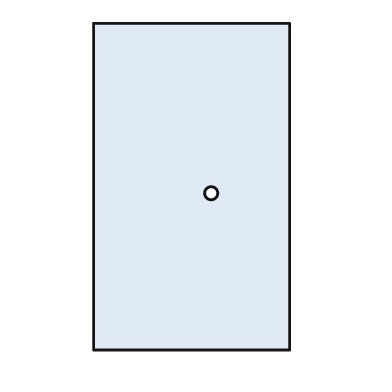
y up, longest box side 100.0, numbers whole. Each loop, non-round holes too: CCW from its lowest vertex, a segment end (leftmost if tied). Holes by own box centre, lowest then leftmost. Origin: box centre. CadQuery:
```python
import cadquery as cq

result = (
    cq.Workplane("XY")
    .moveTo(-30.0, -50.0)
    .lineTo(30.0, -50.0)
    .lineTo(30.0, 50.0)
    .lineTo(-30.0, 50.0)
    .close()
    .moveTo(6.0, -2.0)
    .circle(2.0)
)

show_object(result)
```